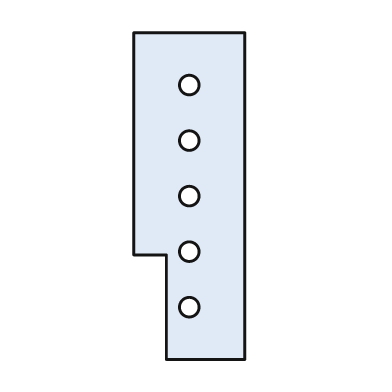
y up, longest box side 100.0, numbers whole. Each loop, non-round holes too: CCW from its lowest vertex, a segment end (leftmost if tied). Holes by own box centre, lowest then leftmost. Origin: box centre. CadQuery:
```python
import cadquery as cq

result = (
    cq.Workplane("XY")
    .moveTo(-7.0, -50.0)
    .lineTo(17.0, -50.0)
    .lineTo(17.0, 50.0)
    .lineTo(-17.0, 50.0)
    .lineTo(-17.0, -18.0)
    .lineTo(-7.0, -18.0)
    .close()
    .moveTo(0.0, -34.0)
    .circle(3.0)
    .moveTo(0.0, -17.0)
    .circle(3.0)
    .moveTo(0.0, 0.0)
    .circle(3.0)
    .moveTo(0.0, 17.0)
    .circle(3.0)
    .moveTo(0.0, 34.0)
    .circle(3.0)
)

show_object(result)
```